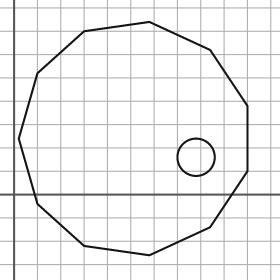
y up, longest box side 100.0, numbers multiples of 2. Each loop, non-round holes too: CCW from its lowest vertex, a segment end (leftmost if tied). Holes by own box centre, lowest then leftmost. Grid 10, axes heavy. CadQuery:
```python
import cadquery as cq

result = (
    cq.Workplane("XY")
    .moveTo(58.0, -26.0)
    .lineTo(84.0, -14.0)
    .lineTo(100.0, 10.0)
    .lineTo(100.0, 38.0)
    .lineTo(84.0, 62.0)
    .lineTo(58.0, 74.0)
    .lineTo(30.0, 70.0)
    .lineTo(10.0, 52.0)
    .lineTo(2.0, 24.0)
    .lineTo(10.0, -4.0)
    .lineTo(30.0, -22.0)
    .close()
    .moveTo(78.0, 16.0)
    .circle(8.0)
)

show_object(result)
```